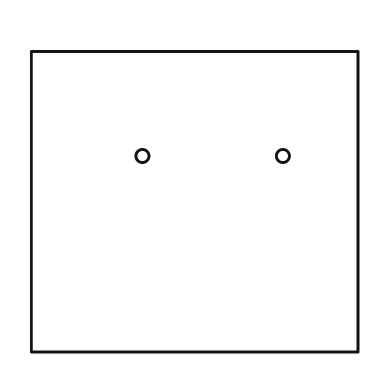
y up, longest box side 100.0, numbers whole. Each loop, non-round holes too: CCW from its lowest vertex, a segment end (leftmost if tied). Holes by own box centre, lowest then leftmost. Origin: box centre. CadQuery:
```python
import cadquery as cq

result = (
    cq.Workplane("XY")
    .moveTo(-50.0, -46.0)
    .lineTo(50.0, -46.0)
    .lineTo(50.0, 46.0)
    .lineTo(-50.0, 46.0)
    .close()
    .moveTo(-16.0, 14.0)
    .circle(2.0)
    .moveTo(27.0, 14.0)
    .circle(2.0)
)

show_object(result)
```